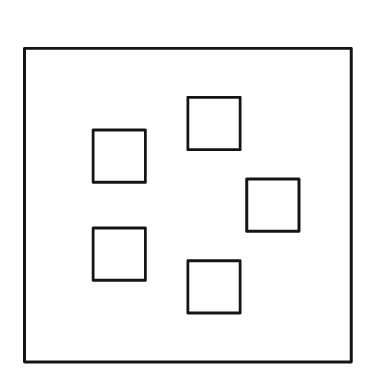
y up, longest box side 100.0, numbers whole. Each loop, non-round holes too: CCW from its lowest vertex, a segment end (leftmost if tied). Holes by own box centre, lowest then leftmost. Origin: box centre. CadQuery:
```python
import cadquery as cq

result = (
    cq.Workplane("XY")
    .moveTo(-50.0, -48.0)
    .lineTo(50.0, -48.0)
    .lineTo(50.0, 48.0)
    .lineTo(-50.0, 48.0)
    .close()
    .moveTo(0.0, -33.0)
    .lineTo(16.0, -33.0)
    .lineTo(16.0, -17.0)
    .lineTo(0.0, -17.0)
    .close()
    .moveTo(-29.0, -23.0)
    .lineTo(-13.0, -23.0)
    .lineTo(-13.0, -7.0)
    .lineTo(-29.0, -7.0)
    .close()
    .moveTo(18.0, -8.0)
    .lineTo(34.0, -8.0)
    .lineTo(34.0, 8.0)
    .lineTo(18.0, 8.0)
    .close()
    .moveTo(-29.0, 7.0)
    .lineTo(-13.0, 7.0)
    .lineTo(-13.0, 23.0)
    .lineTo(-29.0, 23.0)
    .close()
    .moveTo(0.0, 17.0)
    .lineTo(16.0, 17.0)
    .lineTo(16.0, 33.0)
    .lineTo(0.0, 33.0)
    .close()
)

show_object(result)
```